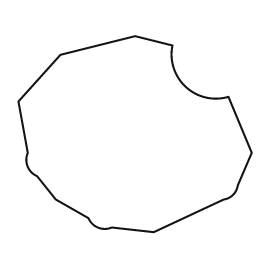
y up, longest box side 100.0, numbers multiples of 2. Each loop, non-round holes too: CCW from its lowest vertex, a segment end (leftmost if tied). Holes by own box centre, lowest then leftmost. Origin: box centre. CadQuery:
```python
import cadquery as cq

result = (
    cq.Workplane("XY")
    .moveTo(8.0, -42.0)
    .lineTo(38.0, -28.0)
    .threePointArc((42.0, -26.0), (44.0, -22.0))
    .lineTo(50.0, -8.0)
    .lineTo(40.0, 16.0)
    .threePointArc((22.0, 20.0), (16.0, 38.0))
    .lineTo(0.0, 42.0)
    .lineTo(-32.0, 34.0)
    .lineTo(-50.0, 14.0)
    .lineTo(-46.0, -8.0)
    .threePointArc((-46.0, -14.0), (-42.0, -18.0))
    .lineTo(-34.0, -28.0)
    .lineTo(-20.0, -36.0)
    .threePointArc((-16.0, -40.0), (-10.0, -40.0))
    .close()
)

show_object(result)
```